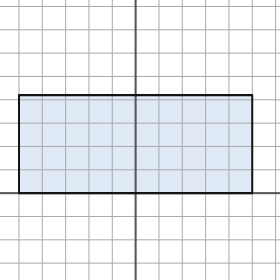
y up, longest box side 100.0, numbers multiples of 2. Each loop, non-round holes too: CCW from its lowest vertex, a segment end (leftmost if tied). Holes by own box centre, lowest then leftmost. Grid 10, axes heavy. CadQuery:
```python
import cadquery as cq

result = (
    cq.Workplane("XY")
    .moveTo(-50.0, 0.0)
    .lineTo(50.0, 0.0)
    .lineTo(50.0, 42.0)
    .lineTo(-50.0, 42.0)
    .close()
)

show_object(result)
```